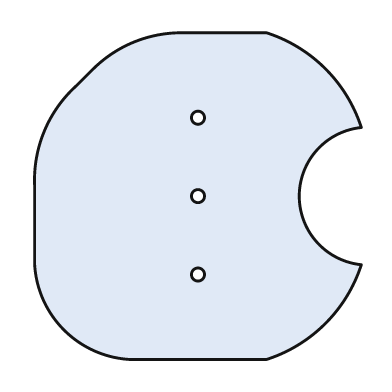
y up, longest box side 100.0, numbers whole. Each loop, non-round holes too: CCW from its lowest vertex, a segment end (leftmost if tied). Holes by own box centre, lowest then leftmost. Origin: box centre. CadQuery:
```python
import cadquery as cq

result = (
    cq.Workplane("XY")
    .moveTo(-21.0, -50.0)
    .lineTo(21.0, -50.0)
    .threePointArc((39.0, -39.0), (50.0, -21.0))
    .threePointArc((31.0, 0.0), (50.0, 21.0))
    .threePointArc((39.0, 39.0), (21.0, 50.0))
    .lineTo(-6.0, 50.0)
    .threePointArc((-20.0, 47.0), (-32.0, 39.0))
    .lineTo(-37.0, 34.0)
    .threePointArc((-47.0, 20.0), (-50.0, 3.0))
    .lineTo(-50.0, -21.0)
    .threePointArc((-41.0, -41.0), (-21.0, -50.0))
    .close()
    .moveTo(0.0, -24.0)
    .circle(2.0)
    .moveTo(0.0, 0.0)
    .circle(2.0)
    .moveTo(0.0, 24.0)
    .circle(2.0)
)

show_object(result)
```